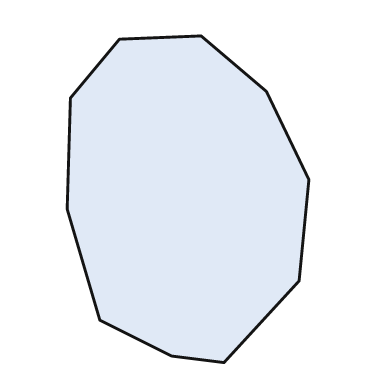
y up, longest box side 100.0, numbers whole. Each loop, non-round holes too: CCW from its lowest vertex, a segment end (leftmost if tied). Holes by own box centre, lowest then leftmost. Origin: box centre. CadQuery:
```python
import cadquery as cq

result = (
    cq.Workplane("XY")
    .moveTo(11.0, -50.0)
    .lineTo(34.0, -25.0)
    .lineTo(37.0, 6.0)
    .lineTo(24.0, 33.0)
    .lineTo(4.0, 50.0)
    .lineTo(-21.0, 49.0)
    .lineTo(-36.0, 31.0)
    .lineTo(-37.0, -3.0)
    .lineTo(-27.0, -37.0)
    .lineTo(-5.0, -48.0)
    .close()
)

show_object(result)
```